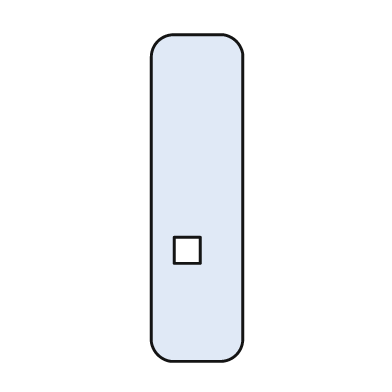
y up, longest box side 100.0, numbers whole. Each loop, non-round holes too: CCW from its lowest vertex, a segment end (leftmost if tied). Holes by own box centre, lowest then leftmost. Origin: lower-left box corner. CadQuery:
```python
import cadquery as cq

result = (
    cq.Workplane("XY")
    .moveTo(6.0, 0.0)
    .lineTo(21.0, 0.0)
    .threePointArc((26.0, 2.0), (28.0, 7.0))
    .lineTo(28.0, 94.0)
    .threePointArc((26.0, 98.0), (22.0, 100.0))
    .lineTo(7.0, 100.0)
    .threePointArc((2.0, 98.0), (0.0, 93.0))
    .lineTo(0.0, 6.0)
    .threePointArc((2.0, 2.0), (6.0, 0.0))
    .close()
    .moveTo(7.0, 30.0)
    .lineTo(15.0, 30.0)
    .lineTo(15.0, 38.0)
    .lineTo(7.0, 38.0)
    .close()
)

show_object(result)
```